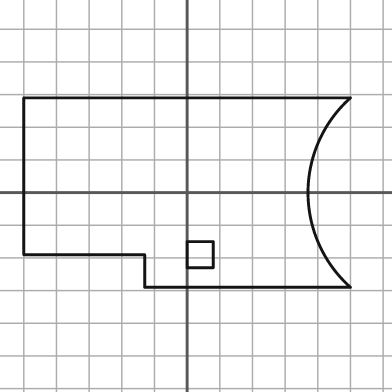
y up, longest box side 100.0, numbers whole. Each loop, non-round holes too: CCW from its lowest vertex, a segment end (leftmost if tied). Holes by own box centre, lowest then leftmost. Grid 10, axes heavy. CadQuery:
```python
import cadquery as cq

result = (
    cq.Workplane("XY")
    .moveTo(-13.0, -29.0)
    .lineTo(50.0, -29.0)
    .threePointArc((37.0, 0.0), (50.0, 29.0))
    .lineTo(-50.0, 29.0)
    .lineTo(-50.0, -19.0)
    .lineTo(-13.0, -19.0)
    .close()
    .moveTo(0.0, -23.0)
    .lineTo(8.0, -23.0)
    .lineTo(8.0, -15.0)
    .lineTo(0.0, -15.0)
    .close()
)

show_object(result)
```